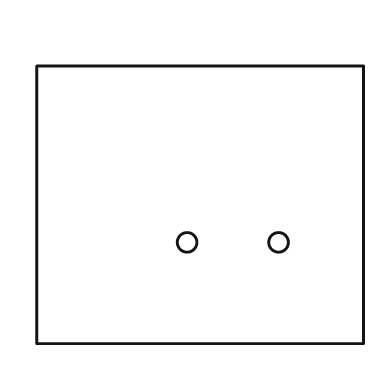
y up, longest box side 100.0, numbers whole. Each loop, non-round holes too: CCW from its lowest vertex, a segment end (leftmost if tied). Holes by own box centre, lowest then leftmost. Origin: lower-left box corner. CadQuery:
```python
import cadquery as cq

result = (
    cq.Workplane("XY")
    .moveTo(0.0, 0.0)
    .lineTo(100.0, 0.0)
    .lineTo(100.0, 85.0)
    .lineTo(0.0, 85.0)
    .close()
    .moveTo(46.0, 31.0)
    .circle(3.0)
    .moveTo(74.0, 31.0)
    .circle(3.0)
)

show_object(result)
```